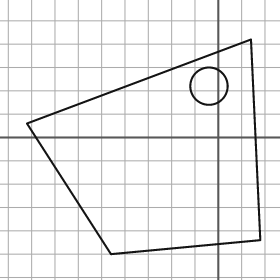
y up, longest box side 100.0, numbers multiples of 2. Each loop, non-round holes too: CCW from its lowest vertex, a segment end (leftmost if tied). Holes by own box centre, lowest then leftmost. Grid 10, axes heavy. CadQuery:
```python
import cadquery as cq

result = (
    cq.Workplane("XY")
    .moveTo(-46.0, -50.0)
    .lineTo(18.0, -44.0)
    .lineTo(14.0, 42.0)
    .lineTo(-82.0, 6.0)
    .close()
    .moveTo(-4.0, 22.0)
    .circle(8.0)
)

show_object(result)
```